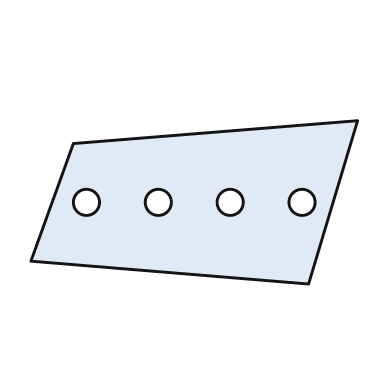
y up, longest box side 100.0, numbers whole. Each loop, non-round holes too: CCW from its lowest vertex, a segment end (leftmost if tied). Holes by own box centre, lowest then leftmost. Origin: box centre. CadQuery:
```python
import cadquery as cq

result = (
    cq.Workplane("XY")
    .moveTo(35.0, -25.0)
    .lineTo(50.0, 25.0)
    .lineTo(-37.0, 18.0)
    .lineTo(-50.0, -18.0)
    .close()
    .moveTo(-33.0, 0.0)
    .circle(4.0)
    .moveTo(-11.0, 0.0)
    .circle(4.0)
    .moveTo(11.0, 0.0)
    .circle(4.0)
    .moveTo(33.0, 0.0)
    .circle(4.0)
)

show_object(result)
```